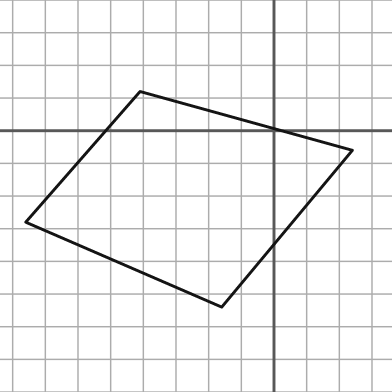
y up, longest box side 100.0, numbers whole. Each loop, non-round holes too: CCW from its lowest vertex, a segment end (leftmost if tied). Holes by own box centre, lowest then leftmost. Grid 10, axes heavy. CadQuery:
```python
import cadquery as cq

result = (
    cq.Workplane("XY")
    .moveTo(-16.0, -54.0)
    .lineTo(24.0, -6.0)
    .lineTo(-41.0, 12.0)
    .lineTo(-76.0, -28.0)
    .close()
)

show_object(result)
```